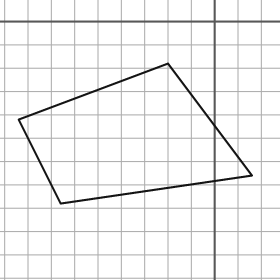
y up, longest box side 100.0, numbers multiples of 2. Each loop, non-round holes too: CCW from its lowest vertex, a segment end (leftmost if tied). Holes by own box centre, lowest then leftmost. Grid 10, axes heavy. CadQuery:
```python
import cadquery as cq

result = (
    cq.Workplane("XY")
    .moveTo(-66.0, -78.0)
    .lineTo(16.0, -66.0)
    .lineTo(-20.0, -18.0)
    .lineTo(-84.0, -42.0)
    .close()
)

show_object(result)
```